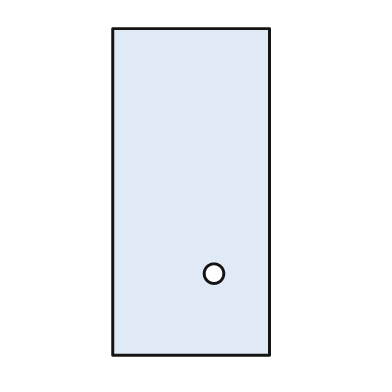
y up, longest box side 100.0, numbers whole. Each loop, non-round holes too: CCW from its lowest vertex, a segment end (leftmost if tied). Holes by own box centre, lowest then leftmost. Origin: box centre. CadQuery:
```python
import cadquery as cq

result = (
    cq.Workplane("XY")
    .moveTo(-24.0, -50.0)
    .lineTo(24.0, -50.0)
    .lineTo(24.0, 50.0)
    .lineTo(-24.0, 50.0)
    .close()
    .moveTo(7.0, -25.0)
    .circle(3.0)
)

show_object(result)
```